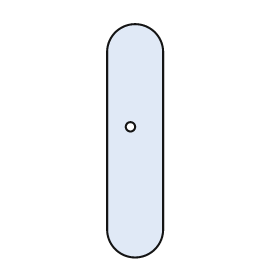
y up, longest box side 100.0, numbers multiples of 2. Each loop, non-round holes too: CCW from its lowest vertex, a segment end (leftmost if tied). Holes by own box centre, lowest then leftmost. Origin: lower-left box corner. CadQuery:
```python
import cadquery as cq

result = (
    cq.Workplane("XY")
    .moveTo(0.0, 12.0)
    .threePointArc((12.0, 0.0), (24.0, 12.0))
    .lineTo(24.0, 88.0)
    .threePointArc((12.0, 100.0), (0.0, 88.0))
    .close()
    .moveTo(10.0, 56.0)
    .circle(2.0)
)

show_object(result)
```